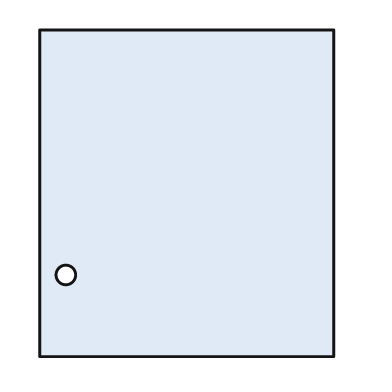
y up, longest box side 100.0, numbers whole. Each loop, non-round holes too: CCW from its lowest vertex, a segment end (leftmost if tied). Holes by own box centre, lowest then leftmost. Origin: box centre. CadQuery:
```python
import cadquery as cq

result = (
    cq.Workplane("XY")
    .moveTo(-45.0, -50.0)
    .lineTo(45.0, -50.0)
    .lineTo(45.0, 50.0)
    .lineTo(-45.0, 50.0)
    .close()
    .moveTo(-37.0, -25.0)
    .circle(3.0)
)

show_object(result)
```